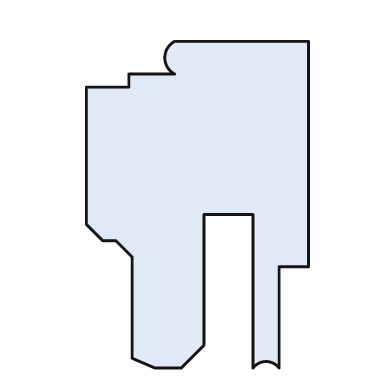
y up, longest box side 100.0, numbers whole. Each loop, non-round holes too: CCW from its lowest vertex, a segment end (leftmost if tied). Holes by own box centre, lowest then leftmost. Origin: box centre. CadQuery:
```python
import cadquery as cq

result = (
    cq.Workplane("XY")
    .moveTo(-13.0, -50.0)
    .lineTo(-5.0, -50.0)
    .lineTo(2.0, -43.0)
    .lineTo(2.0, -3.0)
    .lineTo(17.0, -3.0)
    .lineTo(17.0, -50.0)
    .threePointArc((21.0, -48.0), (25.0, -50.0))
    .lineTo(25.0, -19.0)
    .lineTo(34.0, -19.0)
    .lineTo(34.0, 50.0)
    .lineTo(-7.0, 50.0)
    .threePointArc((-10.0, 45.0), (-7.0, 40.0))
    .lineTo(-21.0, 40.0)
    .lineTo(-21.0, 36.0)
    .lineTo(-34.0, 36.0)
    .lineTo(-34.0, -6.0)
    .lineTo(-29.0, -11.0)
    .lineTo(-25.0, -11.0)
    .lineTo(-20.0, -16.0)
    .lineTo(-20.0, -47.0)
    .close()
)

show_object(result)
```